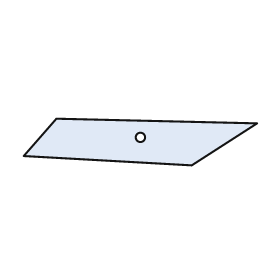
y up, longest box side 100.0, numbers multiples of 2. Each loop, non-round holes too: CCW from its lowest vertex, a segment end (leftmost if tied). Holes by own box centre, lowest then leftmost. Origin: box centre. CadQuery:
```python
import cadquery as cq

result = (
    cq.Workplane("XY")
    .moveTo(22.0, -10.0)
    .lineTo(50.0, 8.0)
    .lineTo(-36.0, 10.0)
    .lineTo(-50.0, -6.0)
    .close()
    .moveTo(0.0, 2.0)
    .circle(2.0)
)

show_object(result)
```